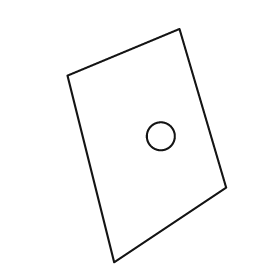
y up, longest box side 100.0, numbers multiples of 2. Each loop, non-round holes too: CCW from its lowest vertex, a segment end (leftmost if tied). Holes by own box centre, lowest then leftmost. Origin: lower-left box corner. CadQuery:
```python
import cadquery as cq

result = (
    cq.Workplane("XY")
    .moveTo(20.0, 0.0)
    .lineTo(68.0, 32.0)
    .lineTo(48.0, 100.0)
    .lineTo(0.0, 80.0)
    .close()
    .moveTo(40.0, 54.0)
    .circle(6.0)
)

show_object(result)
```